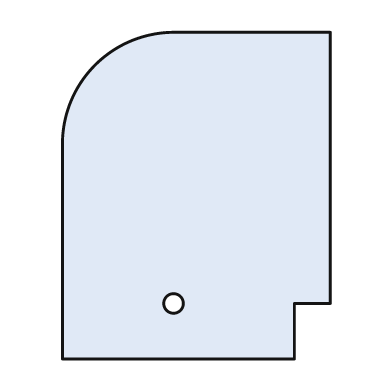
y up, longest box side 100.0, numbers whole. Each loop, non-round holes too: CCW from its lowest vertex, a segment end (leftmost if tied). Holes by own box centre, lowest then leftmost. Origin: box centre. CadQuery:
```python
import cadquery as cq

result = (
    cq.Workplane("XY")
    .moveTo(-41.0, -50.0)
    .lineTo(30.0, -50.0)
    .lineTo(30.0, -33.0)
    .lineTo(41.0, -33.0)
    .lineTo(41.0, 50.0)
    .lineTo(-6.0, 50.0)
    .threePointArc((-31.0, 40.0), (-41.0, 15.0))
    .close()
    .moveTo(-7.0, -33.0)
    .circle(3.0)
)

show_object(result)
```